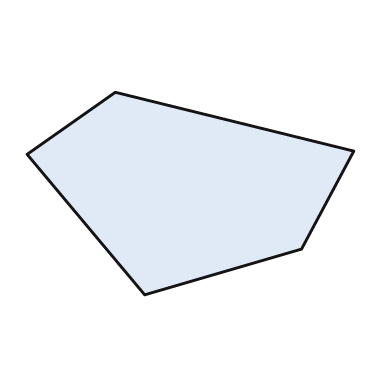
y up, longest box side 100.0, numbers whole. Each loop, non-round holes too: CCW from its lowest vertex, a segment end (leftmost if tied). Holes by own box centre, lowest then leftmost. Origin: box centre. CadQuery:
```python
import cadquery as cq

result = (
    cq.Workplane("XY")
    .moveTo(-14.0, -31.0)
    .lineTo(34.0, -17.0)
    .lineTo(50.0, 13.0)
    .lineTo(-23.0, 31.0)
    .lineTo(-50.0, 12.0)
    .close()
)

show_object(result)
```